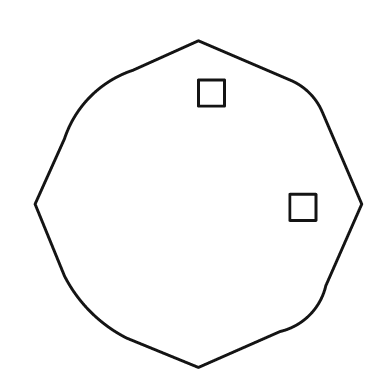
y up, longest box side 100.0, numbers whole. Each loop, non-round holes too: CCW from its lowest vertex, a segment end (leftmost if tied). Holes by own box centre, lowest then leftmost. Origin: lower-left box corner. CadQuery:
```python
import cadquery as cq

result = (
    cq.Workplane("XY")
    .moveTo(50.0, 0.0)
    .lineTo(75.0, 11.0)
    .threePointArc((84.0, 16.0), (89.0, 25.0))
    .lineTo(100.0, 50.0)
    .lineTo(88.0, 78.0)
    .threePointArc((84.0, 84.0), (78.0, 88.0))
    .lineTo(50.0, 100.0)
    .lineTo(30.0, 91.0)
    .threePointArc((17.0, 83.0), (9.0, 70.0))
    .lineTo(0.0, 50.0)
    .lineTo(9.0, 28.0)
    .threePointArc((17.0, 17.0), (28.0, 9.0))
    .close()
    .moveTo(78.0, 45.0)
    .lineTo(86.0, 45.0)
    .lineTo(86.0, 53.0)
    .lineTo(78.0, 53.0)
    .close()
    .moveTo(50.0, 80.0)
    .lineTo(58.0, 80.0)
    .lineTo(58.0, 88.0)
    .lineTo(50.0, 88.0)
    .close()
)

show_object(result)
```